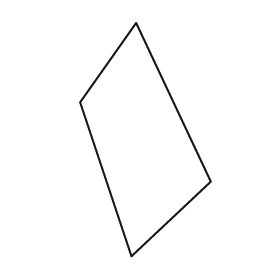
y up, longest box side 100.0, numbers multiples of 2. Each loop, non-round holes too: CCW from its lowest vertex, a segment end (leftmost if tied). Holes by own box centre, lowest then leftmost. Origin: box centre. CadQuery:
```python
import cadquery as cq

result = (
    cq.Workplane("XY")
    .moveTo(-6.0, -50.0)
    .lineTo(28.0, -18.0)
    .lineTo(-4.0, 50.0)
    .lineTo(-28.0, 16.0)
    .close()
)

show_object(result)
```